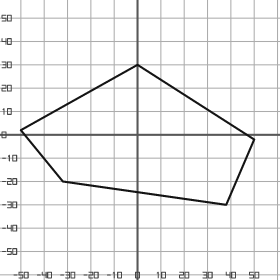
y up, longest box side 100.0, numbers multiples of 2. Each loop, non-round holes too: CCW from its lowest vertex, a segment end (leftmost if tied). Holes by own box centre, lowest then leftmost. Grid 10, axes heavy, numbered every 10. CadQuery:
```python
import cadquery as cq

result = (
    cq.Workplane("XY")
    .moveTo(38.0, -30.0)
    .lineTo(50.0, -2.0)
    .lineTo(0.0, 30.0)
    .lineTo(-50.0, 2.0)
    .lineTo(-32.0, -20.0)
    .close()
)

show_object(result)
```